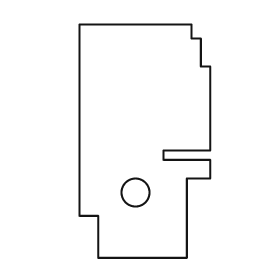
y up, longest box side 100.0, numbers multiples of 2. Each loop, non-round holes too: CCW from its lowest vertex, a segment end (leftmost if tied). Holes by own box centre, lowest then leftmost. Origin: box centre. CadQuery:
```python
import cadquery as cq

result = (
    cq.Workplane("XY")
    .moveTo(-20.0, -50.0)
    .lineTo(18.0, -50.0)
    .lineTo(18.0, -16.0)
    .lineTo(28.0, -16.0)
    .lineTo(28.0, -8.0)
    .lineTo(8.0, -8.0)
    .lineTo(8.0, -4.0)
    .lineTo(28.0, -4.0)
    .lineTo(28.0, 32.0)
    .lineTo(24.0, 32.0)
    .lineTo(24.0, 44.0)
    .lineTo(20.0, 44.0)
    .lineTo(20.0, 50.0)
    .lineTo(-28.0, 50.0)
    .lineTo(-28.0, -32.0)
    .lineTo(-20.0, -32.0)
    .close()
    .moveTo(-4.0, -22.0)
    .circle(6.0)
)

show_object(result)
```